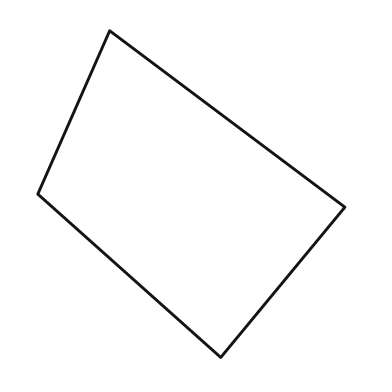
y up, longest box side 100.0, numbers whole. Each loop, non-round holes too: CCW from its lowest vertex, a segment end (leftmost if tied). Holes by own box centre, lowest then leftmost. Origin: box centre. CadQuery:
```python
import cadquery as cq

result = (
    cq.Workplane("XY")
    .moveTo(9.0, -50.0)
    .lineTo(47.0, -4.0)
    .lineTo(-25.0, 50.0)
    .lineTo(-47.0, 0.0)
    .close()
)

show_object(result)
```